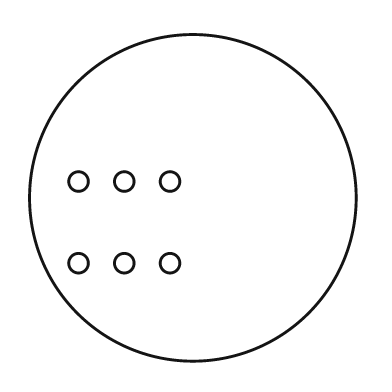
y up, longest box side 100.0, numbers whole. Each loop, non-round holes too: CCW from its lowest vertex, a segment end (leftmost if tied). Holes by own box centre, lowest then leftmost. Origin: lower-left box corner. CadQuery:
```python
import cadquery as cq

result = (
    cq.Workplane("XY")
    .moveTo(50.0, 50.0)
    .circle(50.0)
    .moveTo(15.0, 30.0)
    .circle(3.0)
    .moveTo(29.0, 30.0)
    .circle(3.0)
    .moveTo(43.0, 30.0)
    .circle(3.0)
    .moveTo(15.0, 55.0)
    .circle(3.0)
    .moveTo(29.0, 55.0)
    .circle(3.0)
    .moveTo(43.0, 55.0)
    .circle(3.0)
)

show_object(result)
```